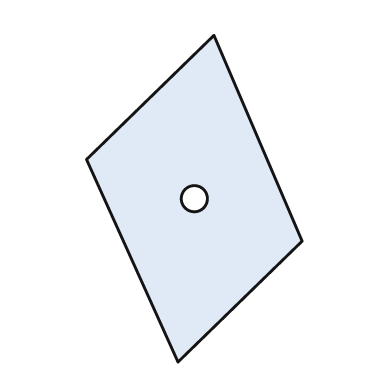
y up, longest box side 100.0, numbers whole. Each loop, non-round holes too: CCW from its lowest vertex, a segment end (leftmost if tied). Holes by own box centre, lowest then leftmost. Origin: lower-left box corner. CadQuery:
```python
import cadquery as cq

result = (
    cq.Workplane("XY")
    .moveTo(28.0, 0.0)
    .lineTo(66.0, 37.0)
    .lineTo(39.0, 100.0)
    .lineTo(0.0, 62.0)
    .close()
    .moveTo(33.0, 50.0)
    .circle(4.0)
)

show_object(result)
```